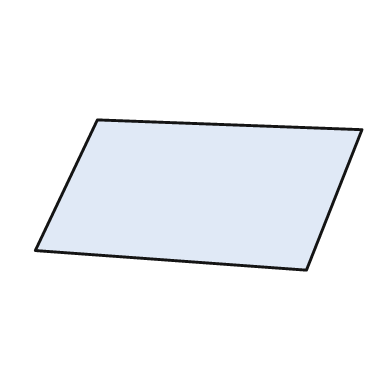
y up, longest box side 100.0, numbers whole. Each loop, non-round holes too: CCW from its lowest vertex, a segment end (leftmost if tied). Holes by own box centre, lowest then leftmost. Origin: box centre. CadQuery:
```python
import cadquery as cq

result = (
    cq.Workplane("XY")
    .moveTo(33.0, -23.0)
    .lineTo(50.0, 20.0)
    .lineTo(-31.0, 23.0)
    .lineTo(-50.0, -17.0)
    .close()
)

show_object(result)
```